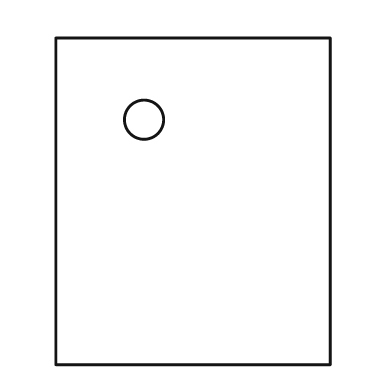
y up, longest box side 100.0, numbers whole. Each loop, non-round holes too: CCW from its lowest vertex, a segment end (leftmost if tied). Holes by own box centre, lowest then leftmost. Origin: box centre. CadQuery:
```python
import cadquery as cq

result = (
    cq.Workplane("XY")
    .moveTo(-42.0, -50.0)
    .lineTo(42.0, -50.0)
    .lineTo(42.0, 50.0)
    .lineTo(-42.0, 50.0)
    .close()
    .moveTo(-15.0, 25.0)
    .circle(6.0)
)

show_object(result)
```